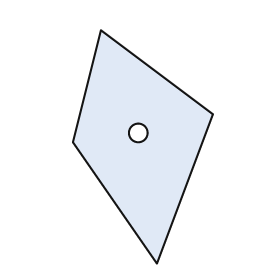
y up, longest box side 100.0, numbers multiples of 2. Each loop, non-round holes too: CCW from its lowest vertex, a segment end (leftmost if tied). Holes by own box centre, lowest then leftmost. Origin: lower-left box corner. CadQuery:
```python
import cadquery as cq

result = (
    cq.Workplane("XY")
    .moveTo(36.0, 0.0)
    .lineTo(60.0, 64.0)
    .lineTo(12.0, 100.0)
    .lineTo(0.0, 52.0)
    .close()
    .moveTo(28.0, 56.0)
    .circle(4.0)
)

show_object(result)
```